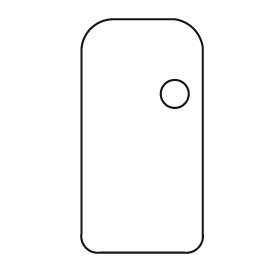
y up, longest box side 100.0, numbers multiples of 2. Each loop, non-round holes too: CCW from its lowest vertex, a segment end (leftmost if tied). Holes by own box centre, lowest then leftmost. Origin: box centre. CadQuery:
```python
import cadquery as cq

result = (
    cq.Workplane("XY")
    .moveTo(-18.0, -50.0)
    .lineTo(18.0, -50.0)
    .threePointArc((24.0, -48.0), (26.0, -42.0))
    .lineTo(26.0, 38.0)
    .threePointArc((22.0, 46.0), (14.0, 50.0))
    .lineTo(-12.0, 50.0)
    .threePointArc((-22.0, 46.0), (-26.0, 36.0))
    .lineTo(-26.0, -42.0)
    .threePointArc((-24.0, -48.0), (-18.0, -50.0))
    .close()
    .moveTo(14.0, 18.0)
    .circle(6.0)
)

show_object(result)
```